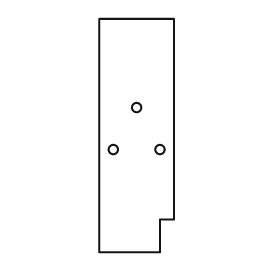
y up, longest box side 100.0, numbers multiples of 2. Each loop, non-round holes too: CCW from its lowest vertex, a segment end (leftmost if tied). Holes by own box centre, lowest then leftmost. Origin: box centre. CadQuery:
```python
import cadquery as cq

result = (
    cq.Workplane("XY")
    .moveTo(-16.0, -50.0)
    .lineTo(10.0, -50.0)
    .lineTo(10.0, -36.0)
    .lineTo(16.0, -36.0)
    .lineTo(16.0, 50.0)
    .lineTo(-16.0, 50.0)
    .close()
    .moveTo(-10.0, -6.0)
    .circle(2.0)
    .moveTo(10.0, -6.0)
    .circle(2.0)
    .moveTo(0.0, 12.0)
    .circle(2.0)
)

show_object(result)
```